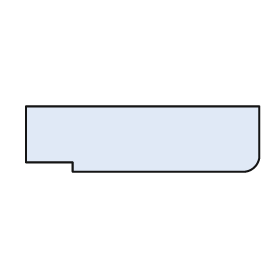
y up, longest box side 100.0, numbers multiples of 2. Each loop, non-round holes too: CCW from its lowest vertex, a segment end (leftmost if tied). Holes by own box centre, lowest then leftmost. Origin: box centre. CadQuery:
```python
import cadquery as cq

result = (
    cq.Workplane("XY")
    .moveTo(-30.0, -14.0)
    .lineTo(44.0, -14.0)
    .threePointArc((48.0, -12.0), (50.0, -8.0))
    .lineTo(50.0, 14.0)
    .lineTo(-50.0, 14.0)
    .lineTo(-50.0, -10.0)
    .lineTo(-30.0, -10.0)
    .close()
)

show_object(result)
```